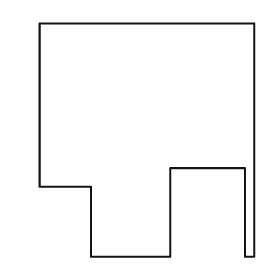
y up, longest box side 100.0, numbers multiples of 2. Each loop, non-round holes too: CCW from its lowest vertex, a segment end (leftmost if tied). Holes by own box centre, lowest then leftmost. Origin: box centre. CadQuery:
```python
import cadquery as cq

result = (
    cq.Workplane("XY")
    .moveTo(-24.0, -50.0)
    .lineTo(10.0, -50.0)
    .lineTo(10.0, -12.0)
    .lineTo(42.0, -12.0)
    .lineTo(42.0, -50.0)
    .lineTo(46.0, -50.0)
    .lineTo(46.0, 50.0)
    .lineTo(-46.0, 50.0)
    .lineTo(-46.0, -20.0)
    .lineTo(-24.0, -20.0)
    .close()
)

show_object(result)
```